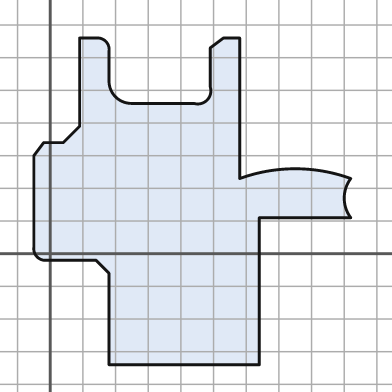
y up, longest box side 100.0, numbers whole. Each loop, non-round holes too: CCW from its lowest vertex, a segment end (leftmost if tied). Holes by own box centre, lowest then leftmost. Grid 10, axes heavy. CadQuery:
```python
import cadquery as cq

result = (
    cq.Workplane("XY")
    .moveTo(18.0, -34.0)
    .lineTo(64.0, -34.0)
    .lineTo(64.0, 11.0)
    .lineTo(92.0, 11.0)
    .threePointArc((90.0, 17.0), (92.0, 23.0))
    .threePointArc((75.0, 26.0), (58.0, 23.0))
    .lineTo(58.0, 66.0)
    .lineTo(53.0, 66.0)
    .lineTo(49.0, 63.0)
    .lineTo(49.0, 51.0)
    .threePointArc((48.0, 47.0), (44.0, 46.0))
    .lineTo(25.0, 46.0)
    .threePointArc((20.0, 48.0), (18.0, 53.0))
    .lineTo(18.0, 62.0)
    .threePointArc((17.0, 65.0), (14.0, 66.0))
    .lineTo(9.0, 66.0)
    .lineTo(9.0, 39.0)
    .lineTo(4.0, 34.0)
    .lineTo(-2.0, 34.0)
    .lineTo(-5.0, 30.0)
    .lineTo(-5.0, 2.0)
    .threePointArc((-4.0, -1.0), (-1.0, -2.0))
    .lineTo(14.0, -2.0)
    .lineTo(18.0, -6.0)
    .close()
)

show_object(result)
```